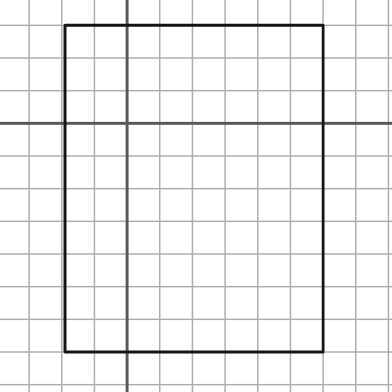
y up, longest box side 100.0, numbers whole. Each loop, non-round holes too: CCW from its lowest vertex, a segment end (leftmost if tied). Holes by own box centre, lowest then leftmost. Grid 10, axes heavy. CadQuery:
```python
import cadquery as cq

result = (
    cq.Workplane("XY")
    .moveTo(-19.0, -70.0)
    .lineTo(60.0, -70.0)
    .lineTo(60.0, 30.0)
    .lineTo(-19.0, 30.0)
    .close()
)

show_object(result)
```